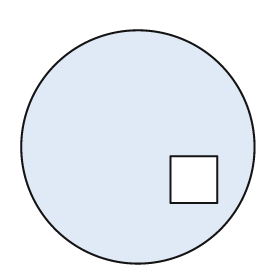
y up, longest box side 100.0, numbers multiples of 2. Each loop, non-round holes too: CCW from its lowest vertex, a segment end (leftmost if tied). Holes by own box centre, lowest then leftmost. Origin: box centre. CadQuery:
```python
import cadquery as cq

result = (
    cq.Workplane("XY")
    .moveTo(0.0, 0.0)
    .circle(50.0)
    .moveTo(14.0, -24.0)
    .lineTo(34.0, -24.0)
    .lineTo(34.0, -4.0)
    .lineTo(14.0, -4.0)
    .close()
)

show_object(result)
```